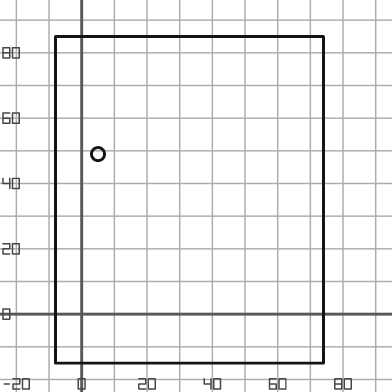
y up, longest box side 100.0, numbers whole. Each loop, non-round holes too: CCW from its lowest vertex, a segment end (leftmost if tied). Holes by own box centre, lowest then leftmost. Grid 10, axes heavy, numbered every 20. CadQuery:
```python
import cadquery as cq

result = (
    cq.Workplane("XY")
    .moveTo(-8.0, -15.0)
    .lineTo(74.0, -15.0)
    .lineTo(74.0, 85.0)
    .lineTo(-8.0, 85.0)
    .close()
    .moveTo(5.0, 49.0)
    .circle(2.0)
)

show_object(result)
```